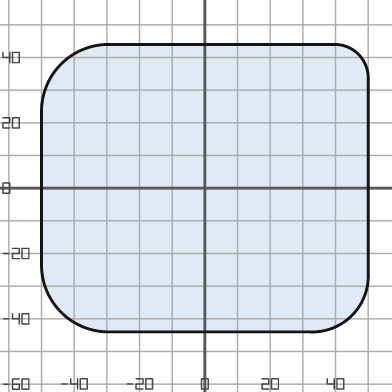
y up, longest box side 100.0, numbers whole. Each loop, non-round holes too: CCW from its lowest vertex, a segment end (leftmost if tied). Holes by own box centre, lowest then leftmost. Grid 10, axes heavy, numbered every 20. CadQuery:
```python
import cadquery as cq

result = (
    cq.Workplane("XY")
    .moveTo(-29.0, -44.0)
    .lineTo(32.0, -44.0)
    .threePointArc((45.0, -39.0), (50.0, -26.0))
    .lineTo(50.0, 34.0)
    .threePointArc((47.0, 41.0), (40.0, 44.0))
    .lineTo(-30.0, 44.0)
    .threePointArc((-44.0, 38.0), (-50.0, 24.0))
    .lineTo(-50.0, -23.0)
    .threePointArc((-44.0, -38.0), (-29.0, -44.0))
    .close()
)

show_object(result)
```